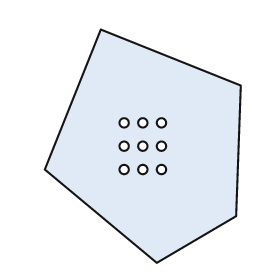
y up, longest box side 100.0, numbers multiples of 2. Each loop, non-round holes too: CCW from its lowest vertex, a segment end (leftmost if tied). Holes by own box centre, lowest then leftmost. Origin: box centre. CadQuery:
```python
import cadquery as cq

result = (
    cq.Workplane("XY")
    .moveTo(6.0, -50.0)
    .lineTo(40.0, -30.0)
    .lineTo(42.0, 26.0)
    .lineTo(-18.0, 50.0)
    .lineTo(-42.0, -10.0)
    .close()
    .moveTo(-8.0, -10.0)
    .circle(2.0)
    .moveTo(0.0, -10.0)
    .circle(2.0)
    .moveTo(8.0, -10.0)
    .circle(2.0)
    .moveTo(-8.0, 0.0)
    .circle(2.0)
    .moveTo(0.0, 0.0)
    .circle(2.0)
    .moveTo(8.0, 0.0)
    .circle(2.0)
    .moveTo(-8.0, 10.0)
    .circle(2.0)
    .moveTo(0.0, 10.0)
    .circle(2.0)
    .moveTo(8.0, 10.0)
    .circle(2.0)
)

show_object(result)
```